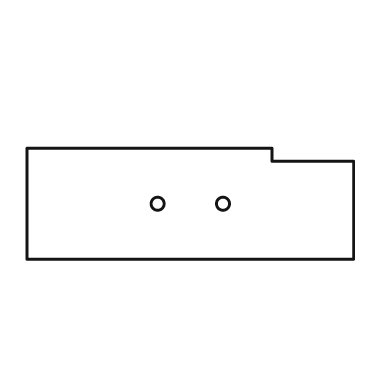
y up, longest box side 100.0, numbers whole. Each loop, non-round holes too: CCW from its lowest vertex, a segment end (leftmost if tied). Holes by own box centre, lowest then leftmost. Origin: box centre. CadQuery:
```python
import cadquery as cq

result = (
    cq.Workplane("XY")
    .moveTo(-50.0, -17.0)
    .lineTo(50.0, -17.0)
    .lineTo(50.0, 13.0)
    .lineTo(25.0, 13.0)
    .lineTo(25.0, 17.0)
    .lineTo(-50.0, 17.0)
    .close()
    .moveTo(-10.0, 0.0)
    .circle(2.0)
    .moveTo(10.0, 0.0)
    .circle(2.0)
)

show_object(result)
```